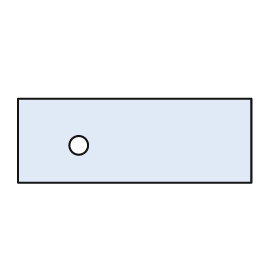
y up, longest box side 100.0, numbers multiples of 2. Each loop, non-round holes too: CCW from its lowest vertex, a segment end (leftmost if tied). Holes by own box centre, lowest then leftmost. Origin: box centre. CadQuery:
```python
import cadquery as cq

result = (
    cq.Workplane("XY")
    .moveTo(-50.0, -18.0)
    .lineTo(50.0, -18.0)
    .lineTo(50.0, 18.0)
    .lineTo(-50.0, 18.0)
    .close()
    .moveTo(-24.0, -2.0)
    .circle(4.0)
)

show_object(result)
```